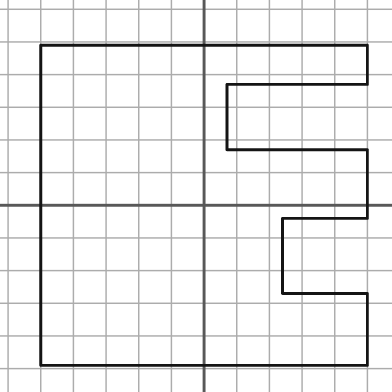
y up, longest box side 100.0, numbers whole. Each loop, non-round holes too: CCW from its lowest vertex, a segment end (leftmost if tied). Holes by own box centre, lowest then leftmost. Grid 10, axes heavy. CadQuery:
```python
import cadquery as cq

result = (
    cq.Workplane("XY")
    .moveTo(-50.0, -49.0)
    .lineTo(50.0, -49.0)
    .lineTo(50.0, -27.0)
    .lineTo(24.0, -27.0)
    .lineTo(24.0, -4.0)
    .lineTo(50.0, -4.0)
    .lineTo(50.0, 17.0)
    .lineTo(7.0, 17.0)
    .lineTo(7.0, 37.0)
    .lineTo(50.0, 37.0)
    .lineTo(50.0, 49.0)
    .lineTo(-50.0, 49.0)
    .close()
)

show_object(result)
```